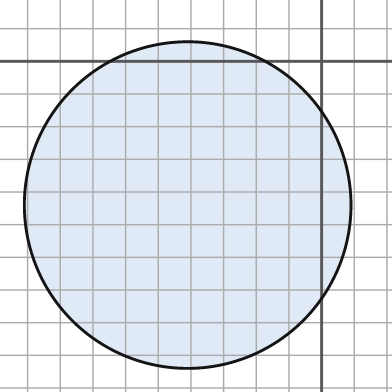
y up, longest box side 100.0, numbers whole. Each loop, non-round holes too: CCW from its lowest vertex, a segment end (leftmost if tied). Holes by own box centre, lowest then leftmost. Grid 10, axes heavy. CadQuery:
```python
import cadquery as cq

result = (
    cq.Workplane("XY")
    .moveTo(-41.0, -44.0)
    .circle(50.0)
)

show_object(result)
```